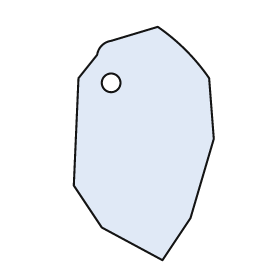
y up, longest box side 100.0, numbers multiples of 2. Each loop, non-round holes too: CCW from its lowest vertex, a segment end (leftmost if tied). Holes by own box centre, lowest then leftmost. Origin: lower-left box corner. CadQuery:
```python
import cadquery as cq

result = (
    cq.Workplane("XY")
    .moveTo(38.0, 0.0)
    .lineTo(50.0, 18.0)
    .lineTo(60.0, 52.0)
    .lineTo(58.0, 78.0)
    .threePointArc((48.0, 90.0), (36.0, 100.0))
    .lineTo(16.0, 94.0)
    .threePointArc((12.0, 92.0), (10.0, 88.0))
    .lineTo(2.0, 78.0)
    .lineTo(0.0, 32.0)
    .lineTo(12.0, 14.0)
    .close()
    .moveTo(16.0, 76.0)
    .circle(4.0)
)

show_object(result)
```